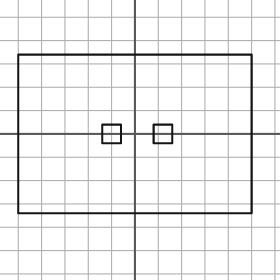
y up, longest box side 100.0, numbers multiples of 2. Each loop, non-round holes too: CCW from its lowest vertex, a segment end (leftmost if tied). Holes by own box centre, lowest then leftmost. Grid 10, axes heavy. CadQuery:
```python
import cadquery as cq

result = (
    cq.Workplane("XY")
    .moveTo(-50.0, -34.0)
    .lineTo(50.0, -34.0)
    .lineTo(50.0, 34.0)
    .lineTo(-50.0, 34.0)
    .close()
    .moveTo(-14.0, -4.0)
    .lineTo(-6.0, -4.0)
    .lineTo(-6.0, 4.0)
    .lineTo(-14.0, 4.0)
    .close()
    .moveTo(8.0, -4.0)
    .lineTo(16.0, -4.0)
    .lineTo(16.0, 4.0)
    .lineTo(8.0, 4.0)
    .close()
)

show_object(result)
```